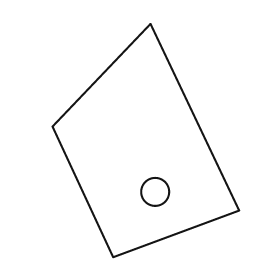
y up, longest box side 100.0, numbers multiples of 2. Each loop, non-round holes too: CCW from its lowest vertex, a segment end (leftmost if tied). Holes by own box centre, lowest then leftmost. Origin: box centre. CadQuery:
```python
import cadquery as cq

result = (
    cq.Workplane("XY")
    .moveTo(-14.0, -50.0)
    .lineTo(40.0, -30.0)
    .lineTo(2.0, 50.0)
    .lineTo(-40.0, 6.0)
    .close()
    .moveTo(4.0, -22.0)
    .circle(6.0)
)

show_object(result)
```